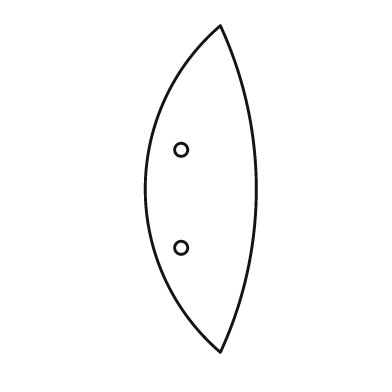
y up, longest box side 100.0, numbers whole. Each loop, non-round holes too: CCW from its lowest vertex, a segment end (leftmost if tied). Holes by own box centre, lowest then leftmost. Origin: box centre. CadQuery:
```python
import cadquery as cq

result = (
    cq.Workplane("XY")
    .moveTo(6.0, -50.0)
    .threePointArc((17.0, 0.0), (6.0, 50.0))
    .threePointArc((-17.0, 0.0), (6.0, -50.0))
    .close()
    .moveTo(-6.0, -18.0)
    .circle(2.0)
    .moveTo(-6.0, 12.0)
    .circle(2.0)
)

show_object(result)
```